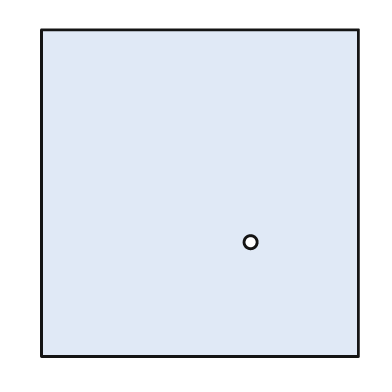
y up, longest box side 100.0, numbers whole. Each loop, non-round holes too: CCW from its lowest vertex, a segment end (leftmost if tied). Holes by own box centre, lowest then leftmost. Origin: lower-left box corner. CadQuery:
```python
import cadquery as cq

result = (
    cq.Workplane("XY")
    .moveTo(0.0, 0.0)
    .lineTo(97.0, 0.0)
    .lineTo(97.0, 100.0)
    .lineTo(0.0, 100.0)
    .close()
    .moveTo(64.0, 35.0)
    .circle(2.0)
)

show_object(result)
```